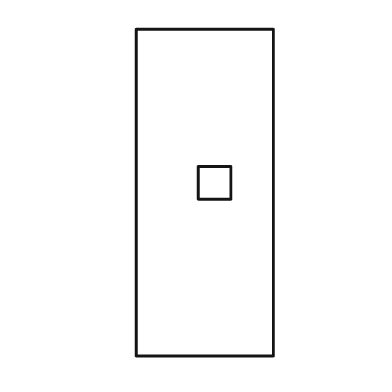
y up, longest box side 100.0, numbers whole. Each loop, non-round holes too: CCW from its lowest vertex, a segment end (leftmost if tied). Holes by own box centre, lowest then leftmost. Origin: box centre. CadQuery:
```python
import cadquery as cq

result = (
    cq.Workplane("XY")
    .moveTo(-21.0, -50.0)
    .lineTo(21.0, -50.0)
    .lineTo(21.0, 50.0)
    .lineTo(-21.0, 50.0)
    .close()
    .moveTo(-2.0, -2.0)
    .lineTo(8.0, -2.0)
    .lineTo(8.0, 8.0)
    .lineTo(-2.0, 8.0)
    .close()
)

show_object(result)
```